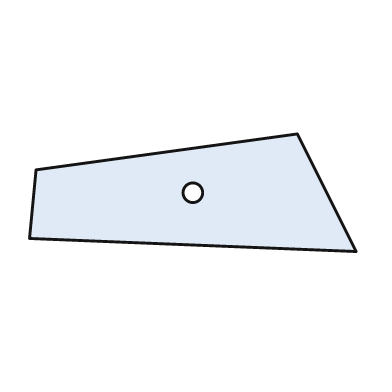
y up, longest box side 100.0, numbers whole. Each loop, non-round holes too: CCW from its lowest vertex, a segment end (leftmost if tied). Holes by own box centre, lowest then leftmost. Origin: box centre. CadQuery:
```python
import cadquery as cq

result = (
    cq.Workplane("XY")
    .moveTo(50.0, -18.0)
    .lineTo(32.0, 18.0)
    .lineTo(-48.0, 7.0)
    .lineTo(-50.0, -14.0)
    .close()
    .moveTo(0.0, 0.0)
    .circle(3.0)
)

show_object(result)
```